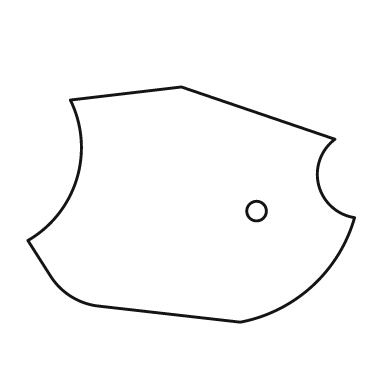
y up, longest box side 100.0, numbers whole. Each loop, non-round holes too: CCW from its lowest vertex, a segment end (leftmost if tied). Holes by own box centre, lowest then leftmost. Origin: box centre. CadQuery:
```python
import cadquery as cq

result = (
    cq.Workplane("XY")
    .moveTo(15.0, -36.0)
    .threePointArc((37.0, -25.0), (50.0, -4.0))
    .threePointArc((39.0, 6.0), (44.0, 20.0))
    .lineTo(-3.0, 36.0)
    .lineTo(-37.0, 32.0)
    .threePointArc((-35.0, 8.0), (-50.0, -11.0))
    .lineTo(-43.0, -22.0)
    .threePointArc((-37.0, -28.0), (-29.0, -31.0))
    .close()
    .moveTo(20.0, -2.0)
    .circle(3.0)
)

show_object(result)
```